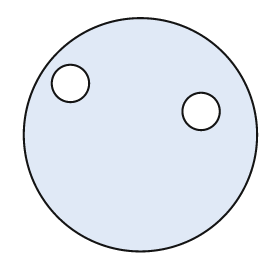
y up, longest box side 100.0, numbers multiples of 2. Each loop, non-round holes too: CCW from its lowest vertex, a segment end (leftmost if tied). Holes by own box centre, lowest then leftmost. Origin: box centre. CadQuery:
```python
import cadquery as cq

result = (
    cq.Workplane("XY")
    .moveTo(0.0, 0.0)
    .circle(50.0)
    .moveTo(26.0, 10.0)
    .circle(8.0)
    .moveTo(-30.0, 22.0)
    .circle(8.0)
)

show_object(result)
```